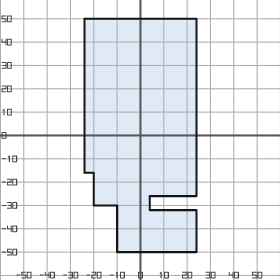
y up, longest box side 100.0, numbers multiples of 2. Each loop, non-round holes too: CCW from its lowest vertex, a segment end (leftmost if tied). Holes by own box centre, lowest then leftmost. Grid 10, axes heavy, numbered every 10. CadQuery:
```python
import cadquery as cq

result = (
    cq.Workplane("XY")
    .moveTo(-10.0, -50.0)
    .lineTo(24.0, -50.0)
    .lineTo(24.0, -32.0)
    .lineTo(4.0, -32.0)
    .lineTo(4.0, -26.0)
    .lineTo(24.0, -26.0)
    .lineTo(24.0, 50.0)
    .lineTo(-24.0, 50.0)
    .lineTo(-24.0, -16.0)
    .lineTo(-20.0, -16.0)
    .lineTo(-20.0, -30.0)
    .lineTo(-10.0, -30.0)
    .close()
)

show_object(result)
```